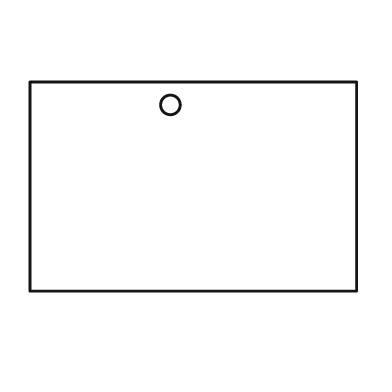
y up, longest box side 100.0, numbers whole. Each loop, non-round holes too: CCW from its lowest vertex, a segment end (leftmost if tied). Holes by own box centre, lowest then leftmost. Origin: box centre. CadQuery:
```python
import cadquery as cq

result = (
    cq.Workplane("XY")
    .moveTo(-50.0, -32.0)
    .lineTo(50.0, -32.0)
    .lineTo(50.0, 32.0)
    .lineTo(-50.0, 32.0)
    .close()
    .moveTo(-7.0, 25.0)
    .circle(3.0)
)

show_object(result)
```